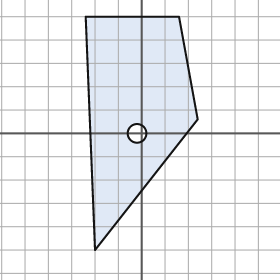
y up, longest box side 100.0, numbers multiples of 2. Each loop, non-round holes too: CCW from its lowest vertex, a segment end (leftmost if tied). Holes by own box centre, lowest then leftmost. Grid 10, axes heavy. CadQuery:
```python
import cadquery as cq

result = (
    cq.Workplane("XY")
    .moveTo(-20.0, -50.0)
    .lineTo(24.0, 6.0)
    .lineTo(16.0, 50.0)
    .lineTo(-24.0, 50.0)
    .close()
    .moveTo(-2.0, 0.0)
    .circle(4.0)
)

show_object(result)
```